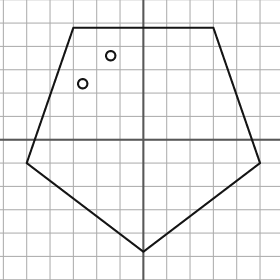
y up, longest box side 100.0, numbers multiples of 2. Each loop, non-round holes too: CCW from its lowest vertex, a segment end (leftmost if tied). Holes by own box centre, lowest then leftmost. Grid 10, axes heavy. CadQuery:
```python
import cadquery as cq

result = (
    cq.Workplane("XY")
    .moveTo(0.0, -48.0)
    .lineTo(50.0, -10.0)
    .lineTo(30.0, 48.0)
    .lineTo(-30.0, 48.0)
    .lineTo(-50.0, -10.0)
    .close()
    .moveTo(-26.0, 24.0)
    .circle(2.0)
    .moveTo(-14.0, 36.0)
    .circle(2.0)
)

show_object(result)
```